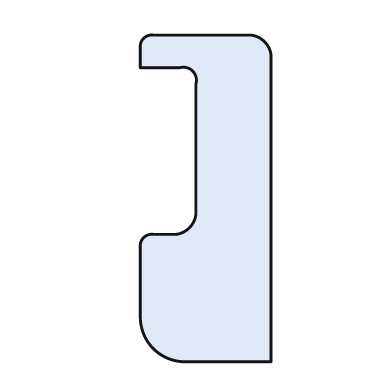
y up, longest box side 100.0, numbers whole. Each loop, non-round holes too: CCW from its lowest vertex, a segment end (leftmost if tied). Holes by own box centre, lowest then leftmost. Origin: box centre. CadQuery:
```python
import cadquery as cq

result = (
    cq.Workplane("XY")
    .moveTo(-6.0, -50.0)
    .lineTo(20.0, -50.0)
    .lineTo(20.0, 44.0)
    .threePointArc((18.0, 48.0), (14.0, 50.0))
    .lineTo(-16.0, 50.0)
    .threePointArc((-19.0, 49.0), (-20.0, 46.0))
    .lineTo(-20.0, 40.0)
    .lineTo(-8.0, 40.0)
    .threePointArc((-4.0, 39.0), (-3.0, 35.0))
    .lineTo(-3.0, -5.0)
    .threePointArc((-5.0, -9.0), (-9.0, -11.0))
    .lineTo(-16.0, -11.0)
    .threePointArc((-19.0, -12.0), (-20.0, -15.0))
    .lineTo(-20.0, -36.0)
    .threePointArc((-16.0, -46.0), (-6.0, -50.0))
    .close()
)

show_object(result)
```